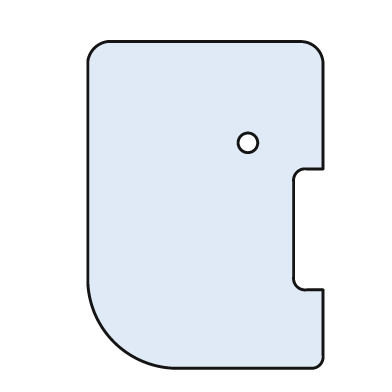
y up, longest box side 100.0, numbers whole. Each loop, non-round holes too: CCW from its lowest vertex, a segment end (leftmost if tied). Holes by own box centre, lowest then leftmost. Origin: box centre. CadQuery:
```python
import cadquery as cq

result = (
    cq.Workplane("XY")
    .moveTo(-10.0, -50.0)
    .lineTo(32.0, -50.0)
    .threePointArc((35.0, -49.0), (36.0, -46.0))
    .lineTo(36.0, -26.0)
    .lineTo(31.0, -26.0)
    .threePointArc((28.0, -25.0), (27.0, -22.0))
    .lineTo(27.0, 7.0)
    .threePointArc((28.0, 10.0), (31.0, 11.0))
    .lineTo(36.0, 11.0)
    .lineTo(36.0, 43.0)
    .threePointArc((34.0, 48.0), (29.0, 50.0))
    .lineTo(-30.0, 50.0)
    .threePointArc((-34.0, 48.0), (-36.0, 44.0))
    .lineTo(-36.0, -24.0)
    .threePointArc((-28.0, -42.0), (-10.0, -50.0))
    .close()
    .moveTo(13.0, 19.0)
    .circle(3.0)
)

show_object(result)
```